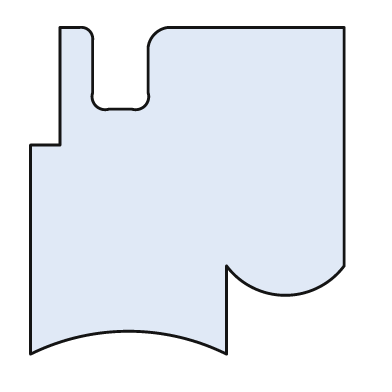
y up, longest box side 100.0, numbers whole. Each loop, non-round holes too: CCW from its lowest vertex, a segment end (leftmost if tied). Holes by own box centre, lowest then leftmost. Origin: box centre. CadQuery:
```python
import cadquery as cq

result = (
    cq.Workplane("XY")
    .moveTo(-48.0, -50.0)
    .threePointArc((-18.0, -43.0), (12.0, -50.0))
    .lineTo(12.0, -23.0)
    .threePointArc((30.0, -32.0), (48.0, -23.0))
    .lineTo(48.0, 50.0)
    .lineTo(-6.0, 50.0)
    .threePointArc((-10.0, 48.0), (-12.0, 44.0))
    .lineTo(-12.0, 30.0)
    .threePointArc((-13.0, 26.0), (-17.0, 25.0))
    .lineTo(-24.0, 25.0)
    .threePointArc((-28.0, 26.0), (-29.0, 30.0))
    .lineTo(-29.0, 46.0)
    .threePointArc((-30.0, 49.0), (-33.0, 50.0))
    .lineTo(-39.0, 50.0)
    .lineTo(-39.0, 14.0)
    .lineTo(-48.0, 14.0)
    .close()
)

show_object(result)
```